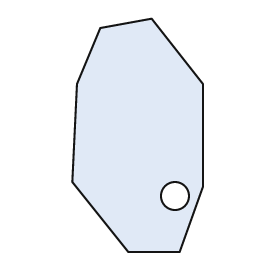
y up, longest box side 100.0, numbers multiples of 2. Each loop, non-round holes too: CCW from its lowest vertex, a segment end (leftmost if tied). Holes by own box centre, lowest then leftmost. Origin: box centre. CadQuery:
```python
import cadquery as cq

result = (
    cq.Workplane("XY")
    .moveTo(-4.0, -50.0)
    .lineTo(18.0, -50.0)
    .lineTo(28.0, -22.0)
    .lineTo(28.0, 22.0)
    .lineTo(6.0, 50.0)
    .lineTo(-16.0, 46.0)
    .lineTo(-26.0, 22.0)
    .lineTo(-28.0, -20.0)
    .close()
    .moveTo(16.0, -26.0)
    .circle(6.0)
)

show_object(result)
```